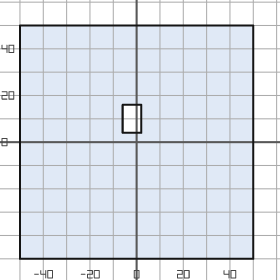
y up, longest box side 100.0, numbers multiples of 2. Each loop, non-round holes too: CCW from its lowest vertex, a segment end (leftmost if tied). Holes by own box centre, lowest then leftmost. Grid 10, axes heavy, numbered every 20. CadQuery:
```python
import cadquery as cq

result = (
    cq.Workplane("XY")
    .moveTo(-50.0, -50.0)
    .lineTo(50.0, -50.0)
    .lineTo(50.0, 50.0)
    .lineTo(-50.0, 50.0)
    .close()
    .moveTo(-6.0, 4.0)
    .lineTo(2.0, 4.0)
    .lineTo(2.0, 16.0)
    .lineTo(-6.0, 16.0)
    .close()
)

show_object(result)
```